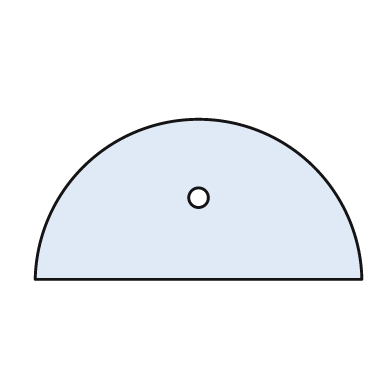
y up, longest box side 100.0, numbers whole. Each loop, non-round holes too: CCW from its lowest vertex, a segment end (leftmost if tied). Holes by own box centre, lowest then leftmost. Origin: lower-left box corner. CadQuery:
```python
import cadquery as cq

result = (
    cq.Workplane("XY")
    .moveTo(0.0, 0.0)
    .lineTo(100.0, 0.0)
    .threePointArc((50.0, 49.0), (0.0, 0.0))
    .close()
    .moveTo(50.0, 25.0)
    .circle(3.0)
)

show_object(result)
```